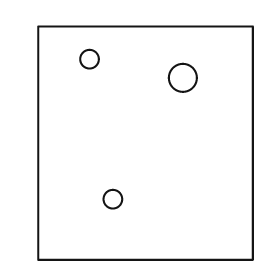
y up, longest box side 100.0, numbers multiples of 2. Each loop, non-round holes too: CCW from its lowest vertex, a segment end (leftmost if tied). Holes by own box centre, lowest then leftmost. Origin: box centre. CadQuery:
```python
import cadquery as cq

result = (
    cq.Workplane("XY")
    .moveTo(-46.0, -50.0)
    .lineTo(46.0, -50.0)
    .lineTo(46.0, 50.0)
    .lineTo(-46.0, 50.0)
    .close()
    .moveTo(-14.0, -24.0)
    .circle(4.0)
    .moveTo(16.0, 28.0)
    .circle(6.0)
    .moveTo(-24.0, 36.0)
    .circle(4.0)
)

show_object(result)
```